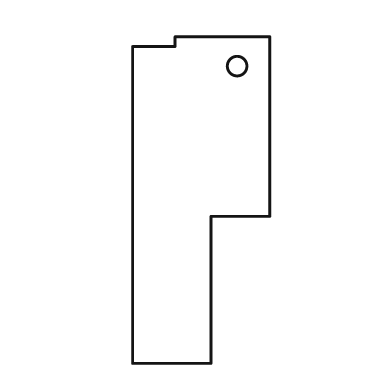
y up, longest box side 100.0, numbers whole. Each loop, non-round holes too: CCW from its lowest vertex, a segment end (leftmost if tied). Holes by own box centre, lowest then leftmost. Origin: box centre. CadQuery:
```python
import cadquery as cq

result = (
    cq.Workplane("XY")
    .moveTo(-21.0, -50.0)
    .lineTo(3.0, -50.0)
    .lineTo(3.0, -5.0)
    .lineTo(21.0, -5.0)
    .lineTo(21.0, 50.0)
    .lineTo(-8.0, 50.0)
    .lineTo(-8.0, 47.0)
    .lineTo(-21.0, 47.0)
    .close()
    .moveTo(11.0, 41.0)
    .circle(3.0)
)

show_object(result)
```